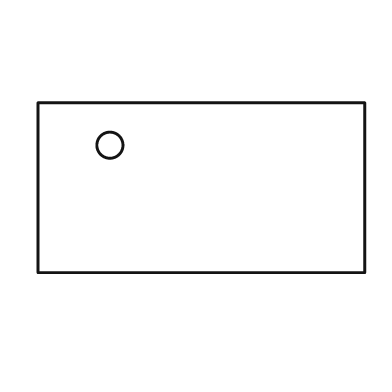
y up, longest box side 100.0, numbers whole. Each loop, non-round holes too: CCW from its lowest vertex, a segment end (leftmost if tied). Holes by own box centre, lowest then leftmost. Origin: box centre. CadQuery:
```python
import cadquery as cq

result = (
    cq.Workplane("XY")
    .moveTo(-50.0, -26.0)
    .lineTo(50.0, -26.0)
    .lineTo(50.0, 26.0)
    .lineTo(-50.0, 26.0)
    .close()
    .moveTo(-28.0, 13.0)
    .circle(4.0)
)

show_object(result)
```